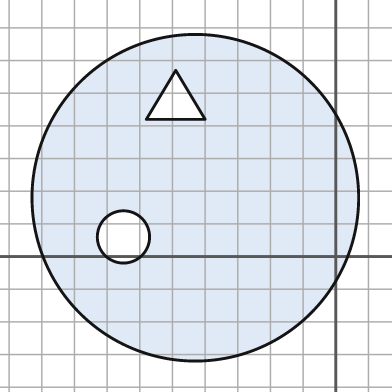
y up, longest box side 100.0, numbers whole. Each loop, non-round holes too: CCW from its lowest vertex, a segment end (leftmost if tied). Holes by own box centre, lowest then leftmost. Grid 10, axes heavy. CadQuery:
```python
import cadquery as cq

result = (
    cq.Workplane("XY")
    .moveTo(-43.0, 18.0)
    .circle(50.0)
    .moveTo(-65.0, 6.0)
    .circle(8.0)
    .moveTo(-58.0, 42.0)
    .lineTo(-40.0, 42.0)
    .lineTo(-49.0, 57.0)
    .close()
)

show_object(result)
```